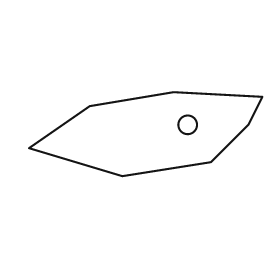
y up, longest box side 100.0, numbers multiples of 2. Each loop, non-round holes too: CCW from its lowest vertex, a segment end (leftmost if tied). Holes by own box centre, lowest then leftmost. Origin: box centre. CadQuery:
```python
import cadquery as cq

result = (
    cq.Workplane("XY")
    .moveTo(-10.0, -18.0)
    .lineTo(28.0, -12.0)
    .lineTo(44.0, 4.0)
    .lineTo(50.0, 16.0)
    .lineTo(12.0, 18.0)
    .lineTo(-24.0, 12.0)
    .lineTo(-50.0, -6.0)
    .close()
    .moveTo(18.0, 4.0)
    .circle(4.0)
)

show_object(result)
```